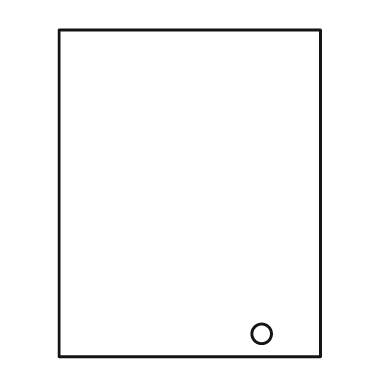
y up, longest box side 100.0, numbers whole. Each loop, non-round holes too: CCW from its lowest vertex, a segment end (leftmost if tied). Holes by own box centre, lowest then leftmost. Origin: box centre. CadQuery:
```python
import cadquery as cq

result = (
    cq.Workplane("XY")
    .moveTo(-40.0, -50.0)
    .lineTo(40.0, -50.0)
    .lineTo(40.0, 50.0)
    .lineTo(-40.0, 50.0)
    .close()
    .moveTo(22.0, -43.0)
    .circle(3.0)
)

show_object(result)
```